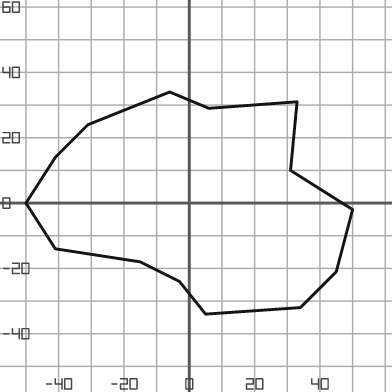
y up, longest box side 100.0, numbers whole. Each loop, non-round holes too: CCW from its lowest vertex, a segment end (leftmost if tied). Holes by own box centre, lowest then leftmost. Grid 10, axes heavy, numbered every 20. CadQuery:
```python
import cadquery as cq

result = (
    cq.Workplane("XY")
    .moveTo(5.0, -34.0)
    .lineTo(34.0, -32.0)
    .lineTo(45.0, -21.0)
    .lineTo(50.0, -2.0)
    .lineTo(31.0, 10.0)
    .lineTo(33.0, 31.0)
    .lineTo(6.0, 29.0)
    .lineTo(-6.0, 34.0)
    .lineTo(-31.0, 24.0)
    .lineTo(-41.0, 14.0)
    .lineTo(-50.0, 0.0)
    .lineTo(-41.0, -14.0)
    .lineTo(-15.0, -18.0)
    .lineTo(-3.0, -24.0)
    .close()
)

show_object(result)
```